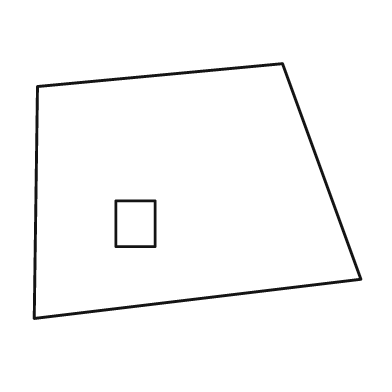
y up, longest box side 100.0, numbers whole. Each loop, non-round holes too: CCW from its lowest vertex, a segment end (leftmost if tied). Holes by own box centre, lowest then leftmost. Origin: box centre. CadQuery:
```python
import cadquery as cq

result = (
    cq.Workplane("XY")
    .moveTo(-50.0, -39.0)
    .lineTo(50.0, -27.0)
    .lineTo(26.0, 39.0)
    .lineTo(-49.0, 32.0)
    .close()
    .moveTo(-25.0, -17.0)
    .lineTo(-13.0, -17.0)
    .lineTo(-13.0, -3.0)
    .lineTo(-25.0, -3.0)
    .close()
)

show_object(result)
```